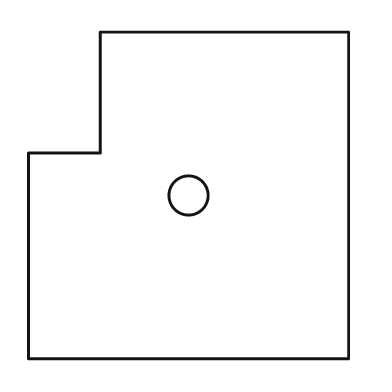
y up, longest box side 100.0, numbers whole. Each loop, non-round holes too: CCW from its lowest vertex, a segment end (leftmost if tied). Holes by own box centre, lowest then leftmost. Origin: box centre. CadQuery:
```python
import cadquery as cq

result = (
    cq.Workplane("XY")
    .moveTo(-49.0, -50.0)
    .lineTo(49.0, -50.0)
    .lineTo(49.0, 50.0)
    .lineTo(-27.0, 50.0)
    .lineTo(-27.0, 13.0)
    .lineTo(-49.0, 13.0)
    .close()
    .moveTo(0.0, 0.0)
    .circle(6.0)
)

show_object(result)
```